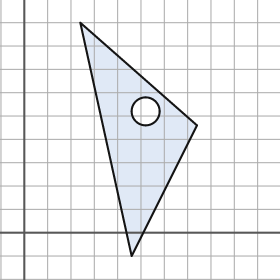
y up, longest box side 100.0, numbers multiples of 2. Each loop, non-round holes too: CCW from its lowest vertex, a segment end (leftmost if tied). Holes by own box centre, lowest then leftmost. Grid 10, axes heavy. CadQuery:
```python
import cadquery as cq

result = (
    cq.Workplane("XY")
    .moveTo(46.0, -10.0)
    .lineTo(74.0, 46.0)
    .lineTo(24.0, 90.0)
    .close()
    .moveTo(52.0, 52.0)
    .circle(6.0)
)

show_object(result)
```